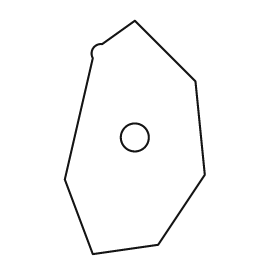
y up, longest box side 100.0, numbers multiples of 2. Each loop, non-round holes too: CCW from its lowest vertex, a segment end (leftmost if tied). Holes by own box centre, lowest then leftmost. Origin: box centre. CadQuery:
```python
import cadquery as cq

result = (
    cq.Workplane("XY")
    .moveTo(-18.0, -50.0)
    .lineTo(10.0, -46.0)
    .lineTo(30.0, -16.0)
    .lineTo(26.0, 24.0)
    .lineTo(0.0, 50.0)
    .lineTo(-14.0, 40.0)
    .threePointArc((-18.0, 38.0), (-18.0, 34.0))
    .lineTo(-30.0, -18.0)
    .close()
    .moveTo(0.0, 0.0)
    .circle(6.0)
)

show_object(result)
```